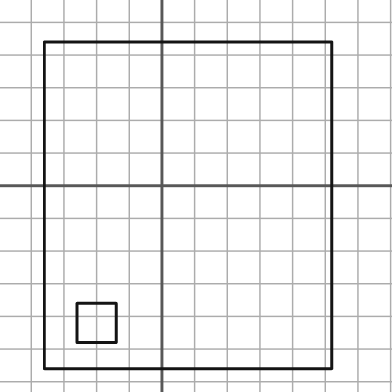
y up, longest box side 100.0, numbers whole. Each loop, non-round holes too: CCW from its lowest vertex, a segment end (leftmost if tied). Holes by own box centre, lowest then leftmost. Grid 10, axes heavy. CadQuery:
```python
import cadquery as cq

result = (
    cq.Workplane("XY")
    .moveTo(-36.0, -56.0)
    .lineTo(52.0, -56.0)
    .lineTo(52.0, 44.0)
    .lineTo(-36.0, 44.0)
    .close()
    .moveTo(-26.0, -48.0)
    .lineTo(-14.0, -48.0)
    .lineTo(-14.0, -36.0)
    .lineTo(-26.0, -36.0)
    .close()
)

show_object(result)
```